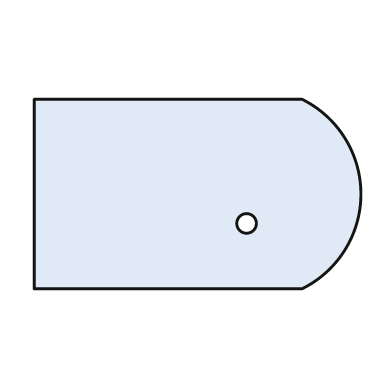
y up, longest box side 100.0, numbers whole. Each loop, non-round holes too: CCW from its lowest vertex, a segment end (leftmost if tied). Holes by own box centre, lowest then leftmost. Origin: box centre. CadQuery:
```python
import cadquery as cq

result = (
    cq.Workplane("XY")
    .moveTo(-50.0, -29.0)
    .lineTo(32.0, -29.0)
    .threePointArc((50.0, 0.0), (32.0, 29.0))
    .lineTo(-50.0, 29.0)
    .close()
    .moveTo(15.0, -9.0)
    .circle(3.0)
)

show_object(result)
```